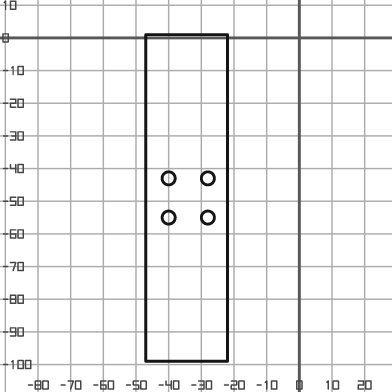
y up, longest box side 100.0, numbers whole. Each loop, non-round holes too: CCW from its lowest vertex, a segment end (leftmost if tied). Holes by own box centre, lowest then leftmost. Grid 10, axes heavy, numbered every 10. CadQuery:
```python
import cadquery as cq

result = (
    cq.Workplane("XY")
    .moveTo(-47.0, -99.0)
    .lineTo(-22.0, -99.0)
    .lineTo(-22.0, 1.0)
    .lineTo(-47.0, 1.0)
    .close()
    .moveTo(-40.0, -55.0)
    .circle(2.0)
    .moveTo(-28.0, -55.0)
    .circle(2.0)
    .moveTo(-40.0, -43.0)
    .circle(2.0)
    .moveTo(-28.0, -43.0)
    .circle(2.0)
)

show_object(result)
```